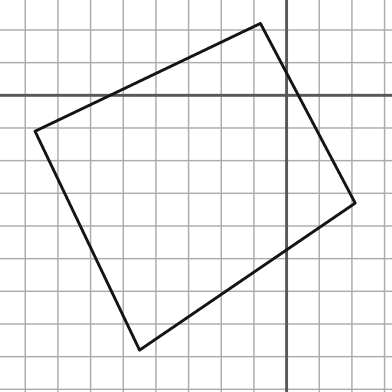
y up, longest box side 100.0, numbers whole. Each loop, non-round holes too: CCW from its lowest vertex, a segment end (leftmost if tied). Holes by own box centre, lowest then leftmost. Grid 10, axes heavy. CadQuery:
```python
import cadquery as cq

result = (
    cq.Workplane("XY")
    .moveTo(-45.0, -78.0)
    .lineTo(21.0, -33.0)
    .lineTo(-8.0, 22.0)
    .lineTo(-77.0, -11.0)
    .close()
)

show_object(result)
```